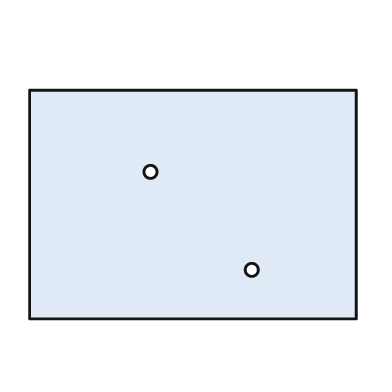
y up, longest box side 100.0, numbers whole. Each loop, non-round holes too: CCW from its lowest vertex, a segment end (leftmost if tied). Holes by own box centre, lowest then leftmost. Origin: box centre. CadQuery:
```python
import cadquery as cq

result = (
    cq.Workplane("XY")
    .moveTo(-50.0, -35.0)
    .lineTo(50.0, -35.0)
    .lineTo(50.0, 35.0)
    .lineTo(-50.0, 35.0)
    .close()
    .moveTo(18.0, -20.0)
    .circle(2.0)
    .moveTo(-13.0, 10.0)
    .circle(2.0)
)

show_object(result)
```